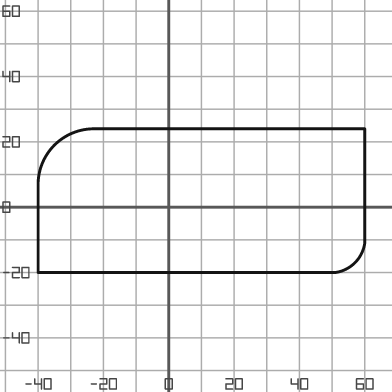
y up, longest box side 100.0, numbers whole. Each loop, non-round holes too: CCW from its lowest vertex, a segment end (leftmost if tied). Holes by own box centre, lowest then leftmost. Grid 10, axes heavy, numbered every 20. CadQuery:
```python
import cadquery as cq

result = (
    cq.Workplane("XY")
    .moveTo(-40.0, -20.0)
    .lineTo(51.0, -20.0)
    .threePointArc((57.0, -17.0), (60.0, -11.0))
    .lineTo(60.0, 24.0)
    .lineTo(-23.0, 24.0)
    .threePointArc((-35.0, 19.0), (-40.0, 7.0))
    .close()
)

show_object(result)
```